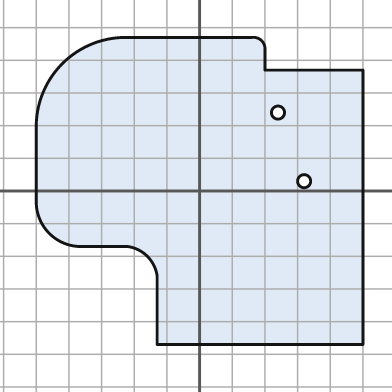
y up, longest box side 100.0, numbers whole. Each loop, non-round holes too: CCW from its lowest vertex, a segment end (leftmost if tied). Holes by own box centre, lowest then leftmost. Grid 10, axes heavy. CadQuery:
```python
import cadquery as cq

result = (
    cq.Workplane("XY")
    .moveTo(-13.0, -47.0)
    .lineTo(50.0, -47.0)
    .lineTo(50.0, 37.0)
    .lineTo(20.0, 37.0)
    .lineTo(20.0, 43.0)
    .threePointArc((19.0, 46.0), (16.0, 47.0))
    .lineTo(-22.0, 47.0)
    .threePointArc((-42.0, 39.0), (-50.0, 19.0))
    .lineTo(-50.0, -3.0)
    .threePointArc((-46.0, -13.0), (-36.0, -17.0))
    .lineTo(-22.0, -17.0)
    .threePointArc((-16.0, -20.0), (-13.0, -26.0))
    .close()
    .moveTo(32.0, 3.0)
    .circle(2.0)
    .moveTo(24.0, 24.0)
    .circle(2.0)
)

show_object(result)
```